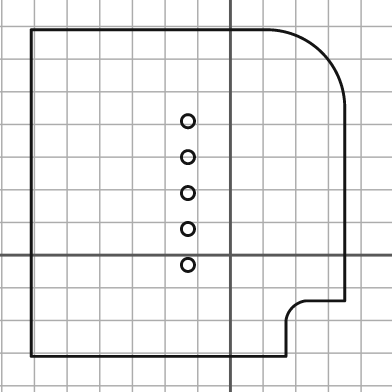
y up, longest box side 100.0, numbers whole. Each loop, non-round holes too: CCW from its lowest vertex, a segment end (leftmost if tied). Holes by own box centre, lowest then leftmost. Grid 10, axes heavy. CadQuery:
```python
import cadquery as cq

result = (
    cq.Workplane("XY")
    .moveTo(-61.0, -31.0)
    .lineTo(17.0, -31.0)
    .lineTo(17.0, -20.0)
    .threePointArc((19.0, -16.0), (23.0, -14.0))
    .lineTo(35.0, -14.0)
    .lineTo(35.0, 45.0)
    .threePointArc((28.0, 62.0), (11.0, 69.0))
    .lineTo(-61.0, 69.0)
    .close()
    .moveTo(-13.0, -3.0)
    .circle(2.0)
    .moveTo(-13.0, 8.0)
    .circle(2.0)
    .moveTo(-13.0, 19.0)
    .circle(2.0)
    .moveTo(-13.0, 30.0)
    .circle(2.0)
    .moveTo(-13.0, 41.0)
    .circle(2.0)
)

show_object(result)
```